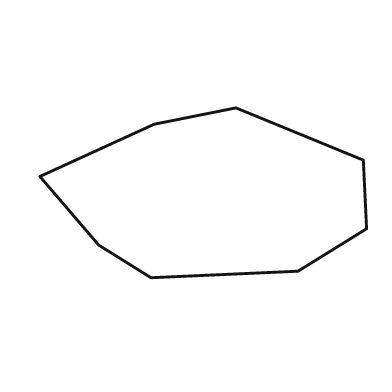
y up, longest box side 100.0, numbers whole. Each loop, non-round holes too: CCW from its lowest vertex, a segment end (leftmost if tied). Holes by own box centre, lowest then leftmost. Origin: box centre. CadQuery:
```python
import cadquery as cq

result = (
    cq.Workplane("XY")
    .moveTo(-16.0, -26.0)
    .lineTo(29.0, -24.0)
    .lineTo(50.0, -11.0)
    .lineTo(49.0, 10.0)
    .lineTo(10.0, 26.0)
    .lineTo(-15.0, 21.0)
    .lineTo(-50.0, 5.0)
    .lineTo(-32.0, -16.0)
    .close()
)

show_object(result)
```